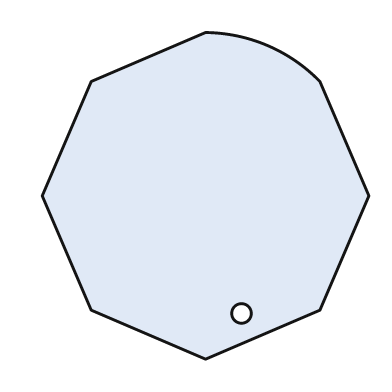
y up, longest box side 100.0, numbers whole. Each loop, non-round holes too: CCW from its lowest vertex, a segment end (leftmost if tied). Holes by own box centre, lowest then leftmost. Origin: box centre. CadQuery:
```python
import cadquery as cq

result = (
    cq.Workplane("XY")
    .moveTo(0.0, -50.0)
    .lineTo(35.0, -35.0)
    .lineTo(50.0, 0.0)
    .lineTo(35.0, 35.0)
    .threePointArc((19.0, 46.0), (0.0, 50.0))
    .lineTo(-35.0, 35.0)
    .lineTo(-50.0, 0.0)
    .lineTo(-35.0, -35.0)
    .close()
    .moveTo(11.0, -36.0)
    .circle(3.0)
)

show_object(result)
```